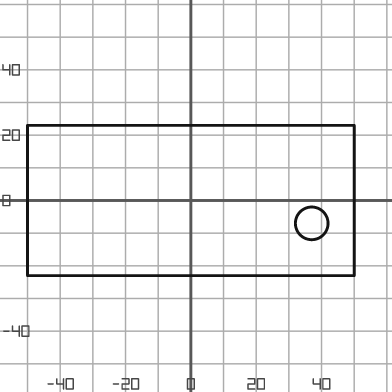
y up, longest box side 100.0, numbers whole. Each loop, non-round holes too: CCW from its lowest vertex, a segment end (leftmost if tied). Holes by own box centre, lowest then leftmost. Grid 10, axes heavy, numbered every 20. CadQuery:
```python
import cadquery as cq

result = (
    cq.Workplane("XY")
    .moveTo(-50.0, -23.0)
    .lineTo(50.0, -23.0)
    .lineTo(50.0, 23.0)
    .lineTo(-50.0, 23.0)
    .close()
    .moveTo(37.0, -7.0)
    .circle(5.0)
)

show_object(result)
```